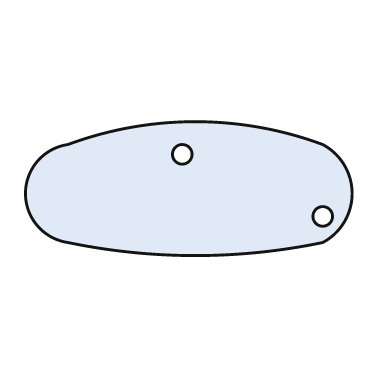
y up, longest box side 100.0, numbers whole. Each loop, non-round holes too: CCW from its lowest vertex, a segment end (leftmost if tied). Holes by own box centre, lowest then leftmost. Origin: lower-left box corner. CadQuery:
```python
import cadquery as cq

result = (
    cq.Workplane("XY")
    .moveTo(13.0, 4.0)
    .threePointArc((52.0, 0.0), (91.0, 4.0))
    .threePointArc((100.0, 19.0), (91.0, 34.0))
    .threePointArc((52.0, 41.0), (13.0, 34.0))
    .threePointArc((0.0, 19.0), (13.0, 4.0))
    .close()
    .moveTo(91.0, 12.0)
    .circle(3.0)
    .moveTo(48.0, 31.0)
    .circle(3.0)
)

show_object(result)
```